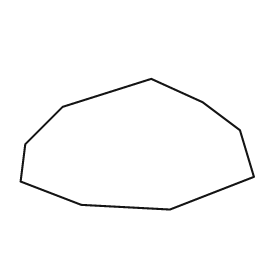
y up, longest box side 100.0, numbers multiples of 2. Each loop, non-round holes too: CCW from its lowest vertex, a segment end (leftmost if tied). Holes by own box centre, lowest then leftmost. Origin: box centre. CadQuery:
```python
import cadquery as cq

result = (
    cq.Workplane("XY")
    .moveTo(14.0, -28.0)
    .lineTo(50.0, -14.0)
    .lineTo(44.0, 6.0)
    .lineTo(28.0, 18.0)
    .lineTo(6.0, 28.0)
    .lineTo(-32.0, 16.0)
    .lineTo(-48.0, 0.0)
    .lineTo(-50.0, -16.0)
    .lineTo(-24.0, -26.0)
    .close()
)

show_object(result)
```